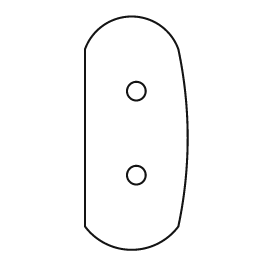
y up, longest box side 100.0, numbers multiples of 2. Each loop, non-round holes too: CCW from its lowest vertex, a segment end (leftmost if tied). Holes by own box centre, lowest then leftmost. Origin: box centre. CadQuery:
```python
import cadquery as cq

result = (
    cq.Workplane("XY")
    .moveTo(-22.0, -40.0)
    .threePointArc((-2.0, -50.0), (18.0, -40.0))
    .threePointArc((22.0, -2.0), (18.0, 36.0))
    .threePointArc((-2.0, 50.0), (-22.0, 36.0))
    .close()
    .moveTo(0.0, -18.0)
    .circle(4.0)
    .moveTo(0.0, 18.0)
    .circle(4.0)
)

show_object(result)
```